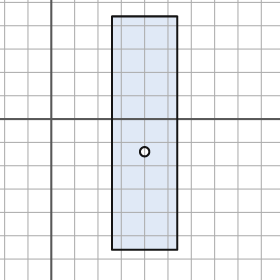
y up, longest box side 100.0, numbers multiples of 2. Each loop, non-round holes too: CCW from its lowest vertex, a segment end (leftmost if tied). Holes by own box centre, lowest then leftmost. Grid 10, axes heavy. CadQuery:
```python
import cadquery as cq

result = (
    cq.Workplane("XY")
    .moveTo(26.0, -56.0)
    .lineTo(54.0, -56.0)
    .lineTo(54.0, 44.0)
    .lineTo(26.0, 44.0)
    .close()
    .moveTo(40.0, -14.0)
    .circle(2.0)
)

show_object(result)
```